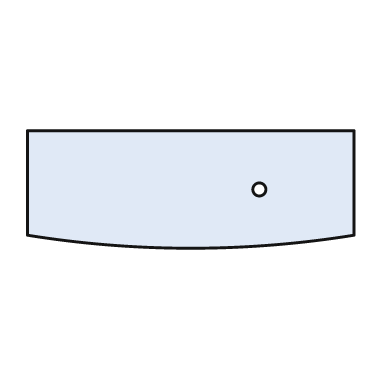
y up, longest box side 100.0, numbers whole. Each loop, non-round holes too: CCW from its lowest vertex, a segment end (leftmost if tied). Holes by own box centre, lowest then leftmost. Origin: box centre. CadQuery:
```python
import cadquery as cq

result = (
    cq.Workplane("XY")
    .moveTo(-50.0, -14.0)
    .threePointArc((0.0, -18.0), (50.0, -14.0))
    .lineTo(50.0, 18.0)
    .lineTo(-50.0, 18.0)
    .close()
    .moveTo(21.0, 0.0)
    .circle(2.0)
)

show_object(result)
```